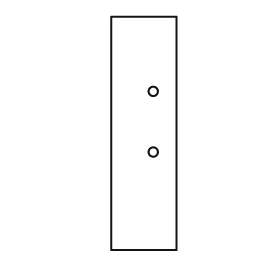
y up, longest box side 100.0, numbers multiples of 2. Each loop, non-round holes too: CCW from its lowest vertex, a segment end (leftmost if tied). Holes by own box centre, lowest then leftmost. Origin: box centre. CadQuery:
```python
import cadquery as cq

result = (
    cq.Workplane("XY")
    .moveTo(-14.0, -50.0)
    .lineTo(14.0, -50.0)
    .lineTo(14.0, 50.0)
    .lineTo(-14.0, 50.0)
    .close()
    .moveTo(4.0, -8.0)
    .circle(2.0)
    .moveTo(4.0, 18.0)
    .circle(2.0)
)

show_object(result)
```